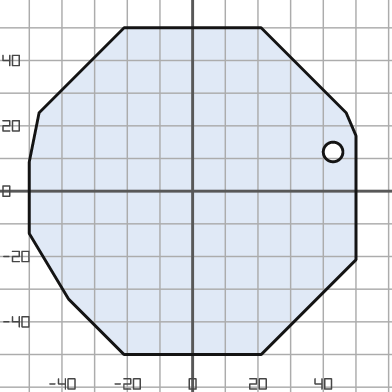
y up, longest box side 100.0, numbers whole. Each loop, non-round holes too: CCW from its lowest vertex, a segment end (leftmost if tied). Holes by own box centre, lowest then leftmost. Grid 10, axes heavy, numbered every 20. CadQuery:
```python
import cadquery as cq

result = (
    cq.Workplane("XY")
    .moveTo(-21.0, -50.0)
    .lineTo(21.0, -50.0)
    .lineTo(50.0, -21.0)
    .lineTo(50.0, 17.0)
    .lineTo(47.0, 24.0)
    .lineTo(21.0, 50.0)
    .lineTo(-21.0, 50.0)
    .lineTo(-47.0, 24.0)
    .lineTo(-50.0, 9.0)
    .lineTo(-50.0, -13.0)
    .lineTo(-38.0, -33.0)
    .close()
    .moveTo(43.0, 12.0)
    .circle(3.0)
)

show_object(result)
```